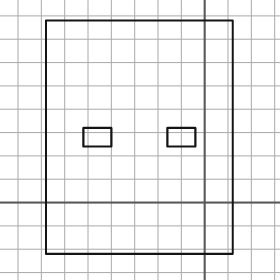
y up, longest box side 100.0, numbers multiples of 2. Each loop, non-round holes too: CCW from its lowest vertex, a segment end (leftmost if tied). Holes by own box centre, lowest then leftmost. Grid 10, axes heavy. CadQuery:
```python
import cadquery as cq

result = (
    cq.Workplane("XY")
    .moveTo(-68.0, -22.0)
    .lineTo(12.0, -22.0)
    .lineTo(12.0, 78.0)
    .lineTo(-68.0, 78.0)
    .close()
    .moveTo(-52.0, 24.0)
    .lineTo(-40.0, 24.0)
    .lineTo(-40.0, 32.0)
    .lineTo(-52.0, 32.0)
    .close()
    .moveTo(-16.0, 24.0)
    .lineTo(-4.0, 24.0)
    .lineTo(-4.0, 32.0)
    .lineTo(-16.0, 32.0)
    .close()
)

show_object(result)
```